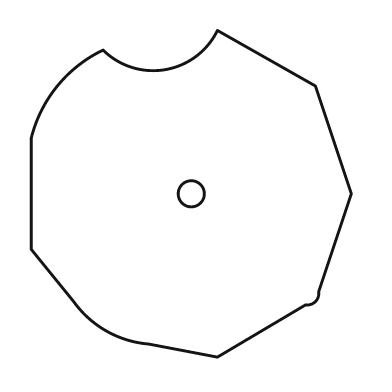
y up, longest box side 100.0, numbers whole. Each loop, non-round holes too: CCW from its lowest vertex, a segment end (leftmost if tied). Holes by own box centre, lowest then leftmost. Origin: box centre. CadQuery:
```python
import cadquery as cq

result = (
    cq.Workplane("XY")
    .moveTo(8.0, -50.0)
    .lineTo(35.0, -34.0)
    .threePointArc((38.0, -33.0), (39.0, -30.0))
    .lineTo(49.0, 0.0)
    .lineTo(38.0, 33.0)
    .lineTo(8.0, 50.0)
    .threePointArc((-8.0, 38.0), (-27.0, 44.0))
    .threePointArc((-41.0, 33.0), (-49.0, 17.0))
    .lineTo(-49.0, -17.0)
    .lineTo(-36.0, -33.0)
    .threePointArc((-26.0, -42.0), (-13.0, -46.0))
    .close()
    .moveTo(0.0, 0.0)
    .circle(4.0)
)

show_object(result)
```